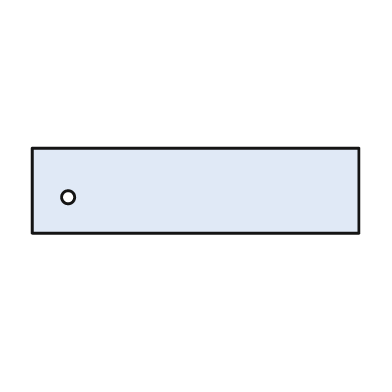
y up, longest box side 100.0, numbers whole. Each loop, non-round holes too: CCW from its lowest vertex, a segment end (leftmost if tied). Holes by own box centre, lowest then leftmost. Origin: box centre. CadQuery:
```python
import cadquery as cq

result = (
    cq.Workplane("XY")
    .moveTo(-50.0, -13.0)
    .lineTo(50.0, -13.0)
    .lineTo(50.0, 13.0)
    .lineTo(-50.0, 13.0)
    .close()
    .moveTo(-39.0, -2.0)
    .circle(2.0)
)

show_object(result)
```